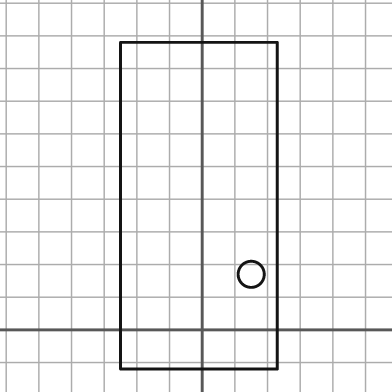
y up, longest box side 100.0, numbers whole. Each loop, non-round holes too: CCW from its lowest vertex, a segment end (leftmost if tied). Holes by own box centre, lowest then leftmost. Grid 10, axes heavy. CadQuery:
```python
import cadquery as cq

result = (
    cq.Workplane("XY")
    .moveTo(-25.0, -12.0)
    .lineTo(23.0, -12.0)
    .lineTo(23.0, 88.0)
    .lineTo(-25.0, 88.0)
    .close()
    .moveTo(15.0, 17.0)
    .circle(4.0)
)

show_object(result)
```